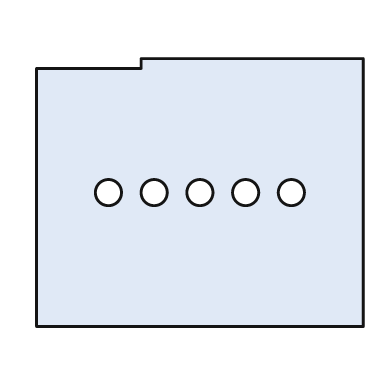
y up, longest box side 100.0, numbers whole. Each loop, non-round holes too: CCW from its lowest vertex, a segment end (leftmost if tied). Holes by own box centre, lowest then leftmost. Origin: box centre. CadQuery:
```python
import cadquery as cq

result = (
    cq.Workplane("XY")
    .moveTo(-50.0, -41.0)
    .lineTo(50.0, -41.0)
    .lineTo(50.0, 41.0)
    .lineTo(-18.0, 41.0)
    .lineTo(-18.0, 38.0)
    .lineTo(-50.0, 38.0)
    .close()
    .moveTo(-28.0, 0.0)
    .circle(4.0)
    .moveTo(-14.0, 0.0)
    .circle(4.0)
    .moveTo(0.0, 0.0)
    .circle(4.0)
    .moveTo(14.0, 0.0)
    .circle(4.0)
    .moveTo(28.0, 0.0)
    .circle(4.0)
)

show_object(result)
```